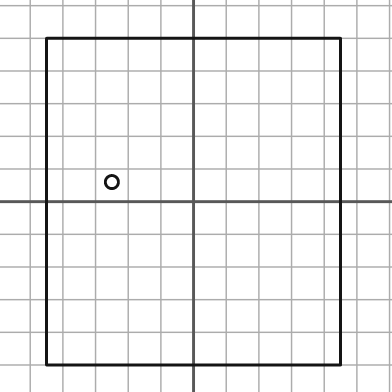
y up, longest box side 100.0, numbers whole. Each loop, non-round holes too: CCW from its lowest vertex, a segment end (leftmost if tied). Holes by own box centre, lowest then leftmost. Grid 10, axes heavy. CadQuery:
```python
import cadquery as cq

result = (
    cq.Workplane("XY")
    .moveTo(-45.0, -50.0)
    .lineTo(45.0, -50.0)
    .lineTo(45.0, 50.0)
    .lineTo(-45.0, 50.0)
    .close()
    .moveTo(-25.0, 6.0)
    .circle(2.0)
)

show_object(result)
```